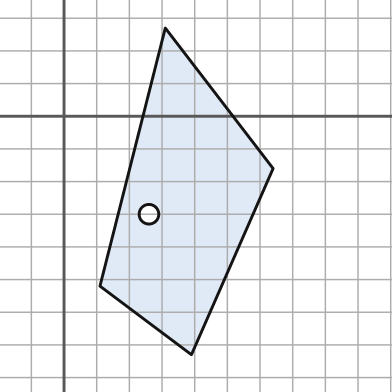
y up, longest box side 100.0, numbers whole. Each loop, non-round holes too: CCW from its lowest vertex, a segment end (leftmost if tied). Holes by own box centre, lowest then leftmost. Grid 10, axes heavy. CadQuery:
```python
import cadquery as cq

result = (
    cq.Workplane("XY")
    .moveTo(39.0, -73.0)
    .lineTo(64.0, -16.0)
    .lineTo(31.0, 27.0)
    .lineTo(11.0, -52.0)
    .close()
    .moveTo(26.0, -30.0)
    .circle(3.0)
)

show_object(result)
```